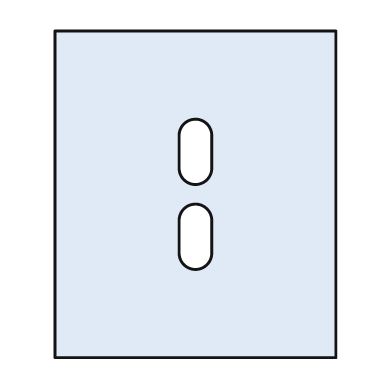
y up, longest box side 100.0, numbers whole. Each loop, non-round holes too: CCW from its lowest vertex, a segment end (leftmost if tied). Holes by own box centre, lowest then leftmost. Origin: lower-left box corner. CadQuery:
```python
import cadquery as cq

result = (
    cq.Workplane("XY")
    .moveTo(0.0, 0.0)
    .lineTo(86.0, 0.0)
    .lineTo(86.0, 100.0)
    .lineTo(0.0, 100.0)
    .close()
    .moveTo(38.0, 32.0)
    .threePointArc((43.0, 27.0), (48.0, 32.0))
    .lineTo(48.0, 42.0)
    .threePointArc((43.0, 47.0), (38.0, 42.0))
    .close()
    .moveTo(38.0, 58.0)
    .threePointArc((43.0, 53.0), (48.0, 58.0))
    .lineTo(48.0, 68.0)
    .threePointArc((43.0, 73.0), (38.0, 68.0))
    .close()
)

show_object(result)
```